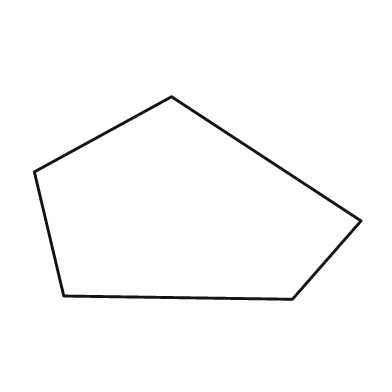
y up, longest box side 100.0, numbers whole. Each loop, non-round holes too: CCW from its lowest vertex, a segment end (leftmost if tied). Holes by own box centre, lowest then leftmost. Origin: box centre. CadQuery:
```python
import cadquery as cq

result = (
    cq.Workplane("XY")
    .moveTo(29.0, -31.0)
    .lineTo(50.0, -7.0)
    .lineTo(-8.0, 31.0)
    .lineTo(-50.0, 8.0)
    .lineTo(-41.0, -30.0)
    .close()
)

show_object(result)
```